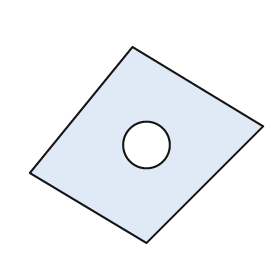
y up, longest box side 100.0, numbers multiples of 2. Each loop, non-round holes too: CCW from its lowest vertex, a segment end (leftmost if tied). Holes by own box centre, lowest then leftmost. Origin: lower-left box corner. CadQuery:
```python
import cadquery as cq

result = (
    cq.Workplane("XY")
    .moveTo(50.0, 0.0)
    .lineTo(100.0, 50.0)
    .lineTo(44.0, 84.0)
    .lineTo(0.0, 30.0)
    .close()
    .moveTo(50.0, 42.0)
    .circle(10.0)
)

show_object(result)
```